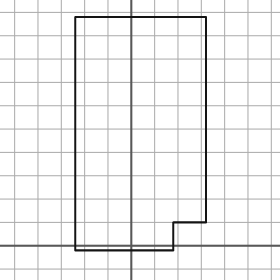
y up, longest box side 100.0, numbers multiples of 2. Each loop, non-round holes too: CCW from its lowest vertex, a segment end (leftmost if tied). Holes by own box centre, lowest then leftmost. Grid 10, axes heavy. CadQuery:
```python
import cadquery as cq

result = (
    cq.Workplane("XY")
    .moveTo(-24.0, -2.0)
    .lineTo(18.0, -2.0)
    .lineTo(18.0, 10.0)
    .lineTo(32.0, 10.0)
    .lineTo(32.0, 98.0)
    .lineTo(-24.0, 98.0)
    .close()
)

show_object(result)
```